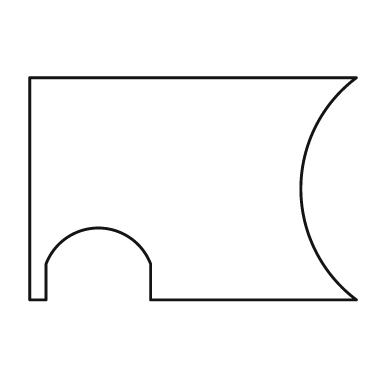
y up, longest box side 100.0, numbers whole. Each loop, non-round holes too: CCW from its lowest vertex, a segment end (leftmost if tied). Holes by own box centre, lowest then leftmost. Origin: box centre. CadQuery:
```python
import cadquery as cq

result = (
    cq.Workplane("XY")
    .moveTo(-50.0, -34.0)
    .lineTo(-45.0, -34.0)
    .lineTo(-45.0, -23.0)
    .threePointArc((-29.0, -12.0), (-13.0, -23.0))
    .lineTo(-13.0, -34.0)
    .lineTo(50.0, -34.0)
    .threePointArc((33.0, 0.0), (50.0, 34.0))
    .lineTo(-50.0, 34.0)
    .close()
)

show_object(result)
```